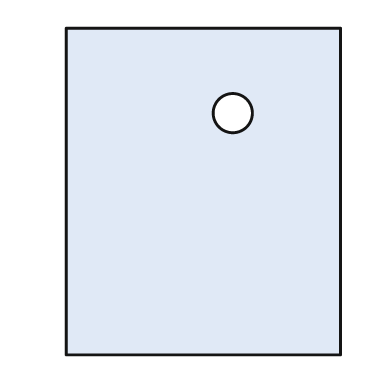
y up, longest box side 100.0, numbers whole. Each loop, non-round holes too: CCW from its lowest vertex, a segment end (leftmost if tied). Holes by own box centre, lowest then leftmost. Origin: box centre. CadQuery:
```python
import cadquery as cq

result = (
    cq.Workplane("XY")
    .moveTo(-42.0, -50.0)
    .lineTo(42.0, -50.0)
    .lineTo(42.0, 50.0)
    .lineTo(-42.0, 50.0)
    .close()
    .moveTo(9.0, 24.0)
    .circle(6.0)
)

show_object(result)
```